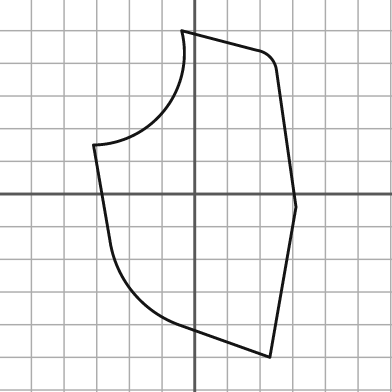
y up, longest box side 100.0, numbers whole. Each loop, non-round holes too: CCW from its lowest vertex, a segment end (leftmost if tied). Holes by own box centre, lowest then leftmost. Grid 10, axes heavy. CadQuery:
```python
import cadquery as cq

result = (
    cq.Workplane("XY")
    .moveTo(23.0, -50.0)
    .lineTo(31.0, -4.0)
    .lineTo(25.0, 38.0)
    .threePointArc((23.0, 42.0), (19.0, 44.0))
    .lineTo(-4.0, 50.0)
    .threePointArc((-9.0, 26.0), (-31.0, 15.0))
    .lineTo(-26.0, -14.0)
    .threePointArc((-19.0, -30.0), (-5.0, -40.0))
    .close()
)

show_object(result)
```